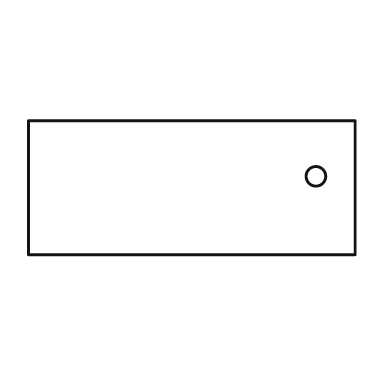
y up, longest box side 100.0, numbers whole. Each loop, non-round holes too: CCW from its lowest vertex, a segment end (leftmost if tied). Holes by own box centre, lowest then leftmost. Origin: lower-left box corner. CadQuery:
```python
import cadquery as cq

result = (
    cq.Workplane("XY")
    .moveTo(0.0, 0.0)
    .lineTo(100.0, 0.0)
    .lineTo(100.0, 41.0)
    .lineTo(0.0, 41.0)
    .close()
    .moveTo(88.0, 24.0)
    .circle(3.0)
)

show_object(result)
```